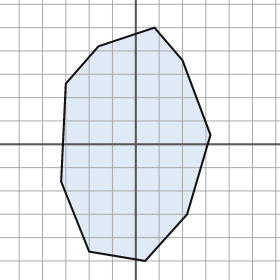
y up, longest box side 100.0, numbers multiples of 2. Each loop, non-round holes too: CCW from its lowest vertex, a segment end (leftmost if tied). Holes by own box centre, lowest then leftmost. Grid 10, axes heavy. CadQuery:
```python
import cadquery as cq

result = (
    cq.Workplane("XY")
    .moveTo(4.0, -50.0)
    .lineTo(22.0, -30.0)
    .lineTo(32.0, 4.0)
    .lineTo(20.0, 36.0)
    .lineTo(8.0, 50.0)
    .lineTo(-16.0, 42.0)
    .lineTo(-30.0, 26.0)
    .lineTo(-32.0, -16.0)
    .lineTo(-20.0, -46.0)
    .close()
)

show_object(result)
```